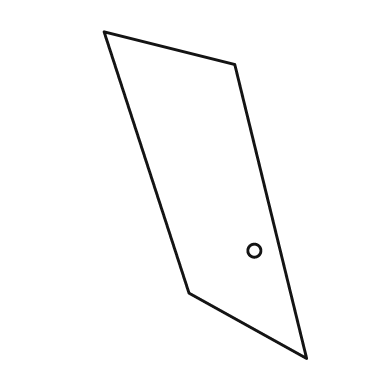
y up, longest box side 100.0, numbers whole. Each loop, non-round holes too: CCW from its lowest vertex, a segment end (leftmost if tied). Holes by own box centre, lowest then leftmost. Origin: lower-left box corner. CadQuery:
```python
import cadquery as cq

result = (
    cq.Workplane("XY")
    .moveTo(62.0, 0.0)
    .lineTo(40.0, 90.0)
    .lineTo(0.0, 100.0)
    .lineTo(26.0, 20.0)
    .close()
    .moveTo(46.0, 33.0)
    .circle(2.0)
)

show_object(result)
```